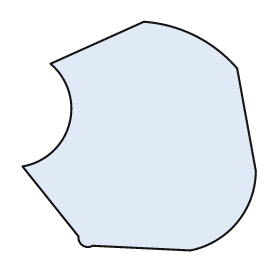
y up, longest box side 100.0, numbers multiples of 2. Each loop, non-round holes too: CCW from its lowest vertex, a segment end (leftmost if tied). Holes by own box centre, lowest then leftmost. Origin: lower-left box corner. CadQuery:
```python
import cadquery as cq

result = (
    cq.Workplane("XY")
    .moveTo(72.0, 0.0)
    .threePointArc((92.0, 12.0), (100.0, 34.0))
    .lineTo(92.0, 78.0)
    .threePointArc((74.0, 92.0), (52.0, 98.0))
    .lineTo(12.0, 80.0)
    .threePointArc((20.0, 54.0), (0.0, 36.0))
    .lineTo(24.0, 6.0)
    .threePointArc((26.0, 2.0), (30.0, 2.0))
    .close()
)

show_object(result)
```